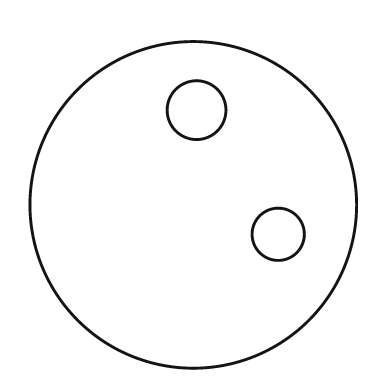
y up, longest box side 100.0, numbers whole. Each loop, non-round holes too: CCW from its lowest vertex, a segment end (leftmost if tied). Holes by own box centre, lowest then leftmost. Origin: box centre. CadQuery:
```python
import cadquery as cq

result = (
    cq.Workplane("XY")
    .moveTo(0.0, 0.0)
    .circle(50.0)
    .moveTo(26.0, -9.0)
    .circle(8.0)
    .moveTo(1.0, 29.0)
    .circle(9.0)
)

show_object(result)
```